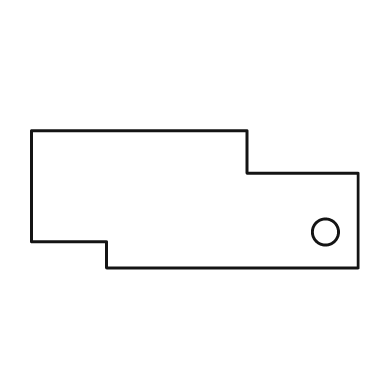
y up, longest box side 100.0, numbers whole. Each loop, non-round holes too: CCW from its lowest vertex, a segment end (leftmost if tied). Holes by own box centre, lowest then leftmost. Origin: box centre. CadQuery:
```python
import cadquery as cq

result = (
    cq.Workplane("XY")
    .moveTo(-27.0, -21.0)
    .lineTo(50.0, -21.0)
    .lineTo(50.0, 8.0)
    .lineTo(16.0, 8.0)
    .lineTo(16.0, 21.0)
    .lineTo(-50.0, 21.0)
    .lineTo(-50.0, -13.0)
    .lineTo(-27.0, -13.0)
    .close()
    .moveTo(40.0, -10.0)
    .circle(4.0)
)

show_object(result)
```